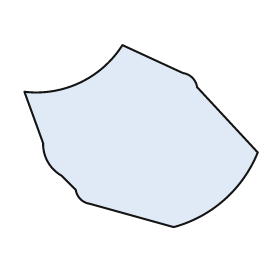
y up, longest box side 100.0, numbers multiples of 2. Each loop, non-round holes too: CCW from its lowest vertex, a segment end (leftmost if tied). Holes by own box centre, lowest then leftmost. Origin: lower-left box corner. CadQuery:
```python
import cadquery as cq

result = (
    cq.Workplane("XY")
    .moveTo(64.0, 0.0)
    .threePointArc((86.0, 12.0), (100.0, 32.0))
    .lineTo(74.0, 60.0)
    .threePointArc((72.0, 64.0), (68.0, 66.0))
    .lineTo(42.0, 78.0)
    .threePointArc((24.0, 62.0), (0.0, 58.0))
    .lineTo(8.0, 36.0)
    .threePointArc((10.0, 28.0), (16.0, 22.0))
    .lineTo(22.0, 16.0)
    .threePointArc((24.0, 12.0), (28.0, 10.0))
    .close()
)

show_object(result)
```